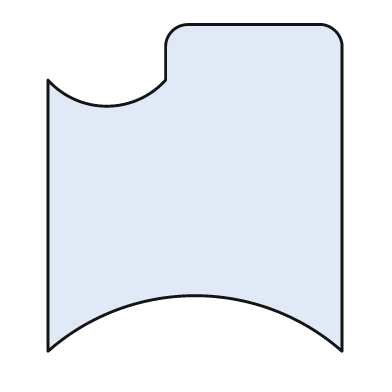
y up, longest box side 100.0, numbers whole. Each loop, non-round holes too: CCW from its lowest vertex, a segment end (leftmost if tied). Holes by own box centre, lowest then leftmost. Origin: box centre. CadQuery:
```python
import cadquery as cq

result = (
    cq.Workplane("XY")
    .moveTo(-45.0, -50.0)
    .threePointArc((0.0, -33.0), (45.0, -50.0))
    .lineTo(45.0, 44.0)
    .threePointArc((43.0, 48.0), (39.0, 50.0))
    .lineTo(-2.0, 50.0)
    .threePointArc((-7.0, 48.0), (-9.0, 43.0))
    .lineTo(-9.0, 33.0)
    .threePointArc((-27.0, 25.0), (-45.0, 33.0))
    .close()
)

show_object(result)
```